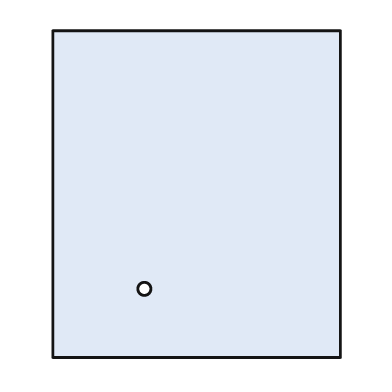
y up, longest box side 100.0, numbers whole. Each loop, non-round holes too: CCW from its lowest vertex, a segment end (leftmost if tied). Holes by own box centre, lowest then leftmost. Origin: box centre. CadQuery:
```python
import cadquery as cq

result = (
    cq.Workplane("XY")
    .moveTo(-44.0, -50.0)
    .lineTo(44.0, -50.0)
    .lineTo(44.0, 50.0)
    .lineTo(-44.0, 50.0)
    .close()
    .moveTo(-16.0, -29.0)
    .circle(2.0)
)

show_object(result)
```